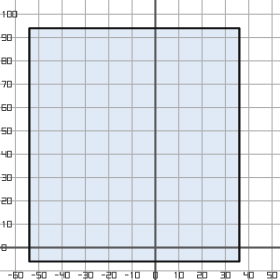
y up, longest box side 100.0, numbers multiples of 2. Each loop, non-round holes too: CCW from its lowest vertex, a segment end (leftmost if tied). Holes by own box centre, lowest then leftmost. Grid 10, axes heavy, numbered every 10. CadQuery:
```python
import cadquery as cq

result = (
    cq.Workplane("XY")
    .moveTo(-54.0, -6.0)
    .lineTo(36.0, -6.0)
    .lineTo(36.0, 94.0)
    .lineTo(-54.0, 94.0)
    .close()
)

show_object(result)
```